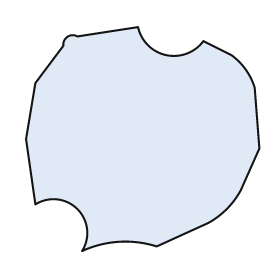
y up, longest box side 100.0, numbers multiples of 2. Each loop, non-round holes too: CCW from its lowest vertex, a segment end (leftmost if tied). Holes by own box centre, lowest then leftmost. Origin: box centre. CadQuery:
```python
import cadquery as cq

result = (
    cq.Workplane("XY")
    .moveTo(-26.0, -48.0)
    .threePointArc((-10.0, -44.0), (6.0, -46.0))
    .lineTo(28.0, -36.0)
    .threePointArc((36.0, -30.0), (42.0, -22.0))
    .lineTo(50.0, -4.0)
    .lineTo(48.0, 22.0)
    .threePointArc((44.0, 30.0), (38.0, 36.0))
    .lineTo(26.0, 42.0)
    .threePointArc((10.0, 36.0), (-2.0, 48.0))
    .lineTo(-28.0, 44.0)
    .threePointArc((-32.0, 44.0), (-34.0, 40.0))
    .lineTo(-46.0, 24.0)
    .lineTo(-50.0, 0.0)
    .lineTo(-46.0, -28.0)
    .threePointArc((-28.0, -30.0), (-26.0, -48.0))
    .close()
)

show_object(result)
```